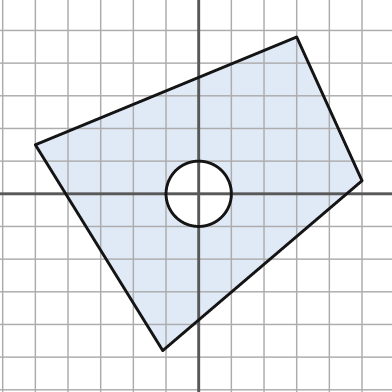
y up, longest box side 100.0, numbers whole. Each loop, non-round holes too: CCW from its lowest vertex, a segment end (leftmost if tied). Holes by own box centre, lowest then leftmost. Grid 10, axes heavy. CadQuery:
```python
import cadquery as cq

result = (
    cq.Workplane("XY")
    .moveTo(-11.0, -48.0)
    .lineTo(50.0, 4.0)
    .lineTo(30.0, 48.0)
    .lineTo(-50.0, 15.0)
    .close()
    .moveTo(0.0, 0.0)
    .circle(10.0)
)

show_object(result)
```